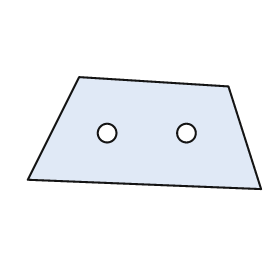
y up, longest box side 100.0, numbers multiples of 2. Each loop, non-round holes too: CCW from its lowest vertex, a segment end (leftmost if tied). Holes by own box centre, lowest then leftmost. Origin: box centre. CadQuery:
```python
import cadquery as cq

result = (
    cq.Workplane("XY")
    .moveTo(50.0, -24.0)
    .lineTo(36.0, 20.0)
    .lineTo(-28.0, 24.0)
    .lineTo(-50.0, -20.0)
    .close()
    .moveTo(-16.0, 0.0)
    .circle(4.0)
    .moveTo(18.0, 0.0)
    .circle(4.0)
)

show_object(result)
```